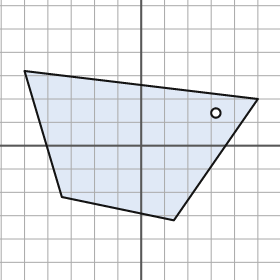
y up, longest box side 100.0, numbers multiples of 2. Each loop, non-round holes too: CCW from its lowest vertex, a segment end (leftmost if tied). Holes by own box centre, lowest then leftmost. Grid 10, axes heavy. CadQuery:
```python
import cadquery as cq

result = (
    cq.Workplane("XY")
    .moveTo(14.0, -32.0)
    .lineTo(50.0, 20.0)
    .lineTo(-50.0, 32.0)
    .lineTo(-34.0, -22.0)
    .close()
    .moveTo(32.0, 14.0)
    .circle(2.0)
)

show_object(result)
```